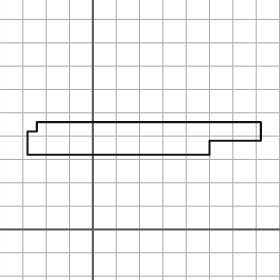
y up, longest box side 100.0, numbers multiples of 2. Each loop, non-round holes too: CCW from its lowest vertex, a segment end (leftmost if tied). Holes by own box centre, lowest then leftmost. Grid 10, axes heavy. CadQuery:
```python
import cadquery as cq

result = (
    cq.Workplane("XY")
    .moveTo(-28.0, 32.0)
    .lineTo(50.0, 32.0)
    .lineTo(50.0, 38.0)
    .lineTo(72.0, 38.0)
    .lineTo(72.0, 46.0)
    .lineTo(-24.0, 46.0)
    .lineTo(-24.0, 42.0)
    .lineTo(-28.0, 42.0)
    .close()
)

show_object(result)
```